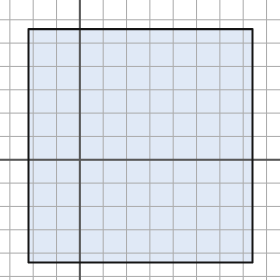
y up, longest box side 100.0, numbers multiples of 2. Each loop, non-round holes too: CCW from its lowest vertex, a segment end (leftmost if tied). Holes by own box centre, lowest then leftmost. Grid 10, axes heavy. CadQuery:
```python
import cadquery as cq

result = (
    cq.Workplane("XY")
    .moveTo(-22.0, -44.0)
    .lineTo(74.0, -44.0)
    .lineTo(74.0, 56.0)
    .lineTo(-22.0, 56.0)
    .close()
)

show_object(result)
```